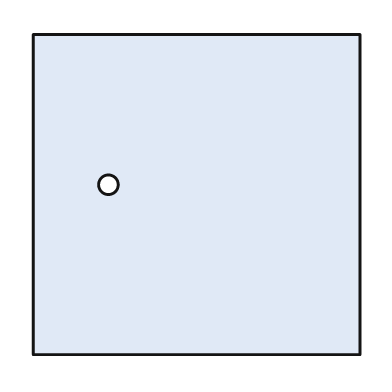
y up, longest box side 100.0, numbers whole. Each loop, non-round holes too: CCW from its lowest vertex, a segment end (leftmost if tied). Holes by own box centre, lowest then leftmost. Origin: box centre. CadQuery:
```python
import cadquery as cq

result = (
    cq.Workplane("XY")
    .moveTo(-50.0, -49.0)
    .lineTo(50.0, -49.0)
    .lineTo(50.0, 49.0)
    .lineTo(-50.0, 49.0)
    .close()
    .moveTo(-27.0, 3.0)
    .circle(3.0)
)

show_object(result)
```